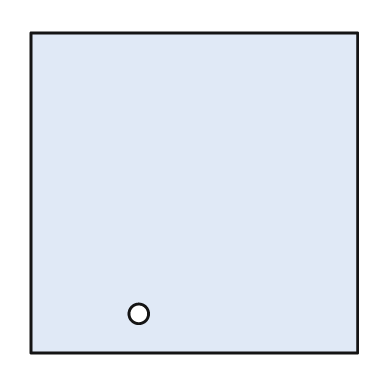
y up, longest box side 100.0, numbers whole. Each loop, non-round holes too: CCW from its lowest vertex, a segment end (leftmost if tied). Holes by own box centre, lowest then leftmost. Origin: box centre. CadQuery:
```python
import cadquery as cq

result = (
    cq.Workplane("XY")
    .moveTo(-50.0, -49.0)
    .lineTo(50.0, -49.0)
    .lineTo(50.0, 49.0)
    .lineTo(-50.0, 49.0)
    .close()
    .moveTo(-17.0, -37.0)
    .circle(3.0)
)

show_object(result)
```